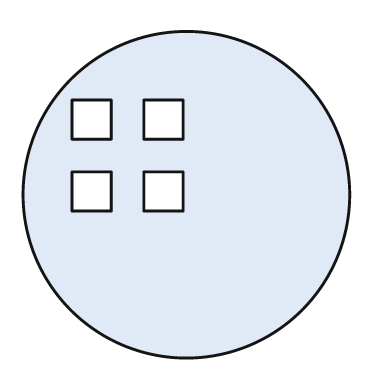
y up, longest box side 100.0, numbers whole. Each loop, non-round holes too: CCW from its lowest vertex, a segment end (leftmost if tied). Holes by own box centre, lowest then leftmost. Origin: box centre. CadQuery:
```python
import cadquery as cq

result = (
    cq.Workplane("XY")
    .moveTo(0.0, 0.0)
    .circle(50.0)
    .moveTo(-35.0, -5.0)
    .lineTo(-23.0, -5.0)
    .lineTo(-23.0, 7.0)
    .lineTo(-35.0, 7.0)
    .close()
    .moveTo(-13.0, -5.0)
    .lineTo(-1.0, -5.0)
    .lineTo(-1.0, 7.0)
    .lineTo(-13.0, 7.0)
    .close()
    .moveTo(-35.0, 17.0)
    .lineTo(-23.0, 17.0)
    .lineTo(-23.0, 29.0)
    .lineTo(-35.0, 29.0)
    .close()
    .moveTo(-13.0, 17.0)
    .lineTo(-1.0, 17.0)
    .lineTo(-1.0, 29.0)
    .lineTo(-13.0, 29.0)
    .close()
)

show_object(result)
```